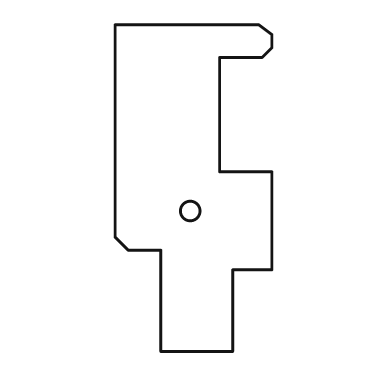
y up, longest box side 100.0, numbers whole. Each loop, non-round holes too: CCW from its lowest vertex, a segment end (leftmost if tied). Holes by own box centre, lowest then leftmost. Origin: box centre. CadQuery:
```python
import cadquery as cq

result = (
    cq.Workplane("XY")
    .moveTo(-10.0, -50.0)
    .lineTo(12.0, -50.0)
    .lineTo(12.0, -25.0)
    .lineTo(24.0, -25.0)
    .lineTo(24.0, 5.0)
    .lineTo(8.0, 5.0)
    .lineTo(8.0, 40.0)
    .lineTo(21.0, 40.0)
    .lineTo(24.0, 43.0)
    .lineTo(24.0, 47.0)
    .lineTo(20.0, 50.0)
    .lineTo(-24.0, 50.0)
    .lineTo(-24.0, -15.0)
    .lineTo(-20.0, -19.0)
    .lineTo(-10.0, -19.0)
    .close()
    .moveTo(-1.0, -7.0)
    .circle(3.0)
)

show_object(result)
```